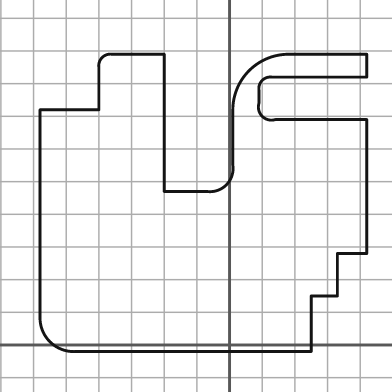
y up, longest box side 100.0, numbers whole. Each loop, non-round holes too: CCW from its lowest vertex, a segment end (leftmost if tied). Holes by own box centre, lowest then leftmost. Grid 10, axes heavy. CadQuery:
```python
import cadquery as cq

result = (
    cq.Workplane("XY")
    .moveTo(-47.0, -2.0)
    .lineTo(25.0, -2.0)
    .lineTo(25.0, 15.0)
    .lineTo(33.0, 15.0)
    .lineTo(33.0, 28.0)
    .lineTo(42.0, 28.0)
    .lineTo(42.0, 69.0)
    .lineTo(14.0, 69.0)
    .threePointArc((10.0, 70.0), (9.0, 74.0))
    .lineTo(9.0, 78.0)
    .threePointArc((10.0, 81.0), (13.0, 82.0))
    .lineTo(42.0, 82.0)
    .lineTo(42.0, 89.0)
    .lineTo(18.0, 89.0)
    .threePointArc((6.0, 84.0), (1.0, 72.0))
    .lineTo(1.0, 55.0)
    .threePointArc((-1.0, 49.0), (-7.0, 47.0))
    .lineTo(-20.0, 47.0)
    .lineTo(-20.0, 89.0)
    .lineTo(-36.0, 89.0)
    .threePointArc((-39.0, 88.0), (-40.0, 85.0))
    .lineTo(-40.0, 72.0)
    .lineTo(-58.0, 72.0)
    .lineTo(-58.0, 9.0)
    .threePointArc((-55.0, 1.0), (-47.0, -2.0))
    .close()
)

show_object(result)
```